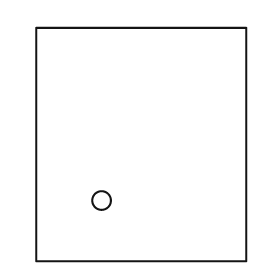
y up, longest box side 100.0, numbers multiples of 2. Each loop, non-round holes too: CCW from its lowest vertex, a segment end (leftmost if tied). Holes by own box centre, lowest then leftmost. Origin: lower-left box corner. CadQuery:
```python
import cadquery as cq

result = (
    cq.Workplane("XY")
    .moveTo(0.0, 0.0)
    .lineTo(90.0, 0.0)
    .lineTo(90.0, 100.0)
    .lineTo(0.0, 100.0)
    .close()
    .moveTo(28.0, 26.0)
    .circle(4.0)
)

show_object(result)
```